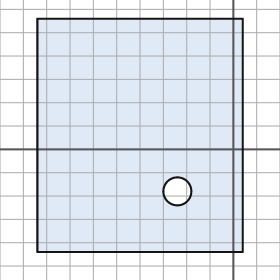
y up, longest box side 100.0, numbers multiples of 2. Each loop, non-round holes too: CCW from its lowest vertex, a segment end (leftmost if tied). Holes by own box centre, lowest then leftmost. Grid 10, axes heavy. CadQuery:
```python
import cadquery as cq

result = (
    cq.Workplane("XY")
    .moveTo(-84.0, -44.0)
    .lineTo(4.0, -44.0)
    .lineTo(4.0, 56.0)
    .lineTo(-84.0, 56.0)
    .close()
    .moveTo(-24.0, -18.0)
    .circle(6.0)
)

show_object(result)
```